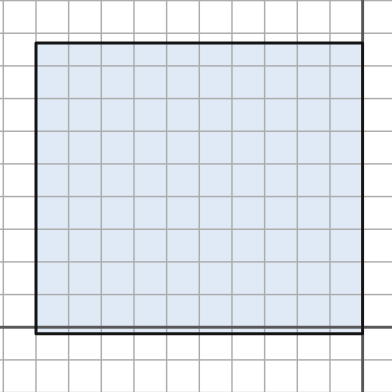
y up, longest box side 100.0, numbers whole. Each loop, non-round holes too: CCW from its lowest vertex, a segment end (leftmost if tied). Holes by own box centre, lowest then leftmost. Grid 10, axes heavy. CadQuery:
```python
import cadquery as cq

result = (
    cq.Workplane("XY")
    .moveTo(-100.0, -2.0)
    .lineTo(0.0, -2.0)
    .lineTo(0.0, 87.0)
    .lineTo(-100.0, 87.0)
    .close()
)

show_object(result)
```